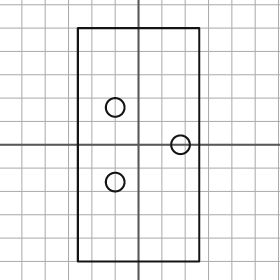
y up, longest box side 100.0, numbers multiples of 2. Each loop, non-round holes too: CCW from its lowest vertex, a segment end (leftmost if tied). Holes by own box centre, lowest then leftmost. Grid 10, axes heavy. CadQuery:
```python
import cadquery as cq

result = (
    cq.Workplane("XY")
    .moveTo(-26.0, -50.0)
    .lineTo(26.0, -50.0)
    .lineTo(26.0, 50.0)
    .lineTo(-26.0, 50.0)
    .close()
    .moveTo(-10.0, -16.0)
    .circle(4.0)
    .moveTo(18.0, 0.0)
    .circle(4.0)
    .moveTo(-10.0, 16.0)
    .circle(4.0)
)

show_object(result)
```